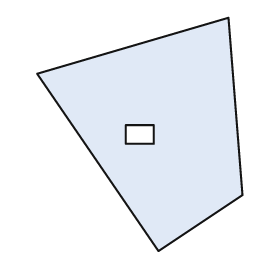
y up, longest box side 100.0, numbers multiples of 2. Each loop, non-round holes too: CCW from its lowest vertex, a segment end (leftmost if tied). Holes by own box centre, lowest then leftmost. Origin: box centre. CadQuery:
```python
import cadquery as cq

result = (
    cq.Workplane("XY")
    .moveTo(8.0, -50.0)
    .lineTo(44.0, -26.0)
    .lineTo(38.0, 50.0)
    .lineTo(-44.0, 26.0)
    .close()
    .moveTo(-6.0, -4.0)
    .lineTo(6.0, -4.0)
    .lineTo(6.0, 4.0)
    .lineTo(-6.0, 4.0)
    .close()
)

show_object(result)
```